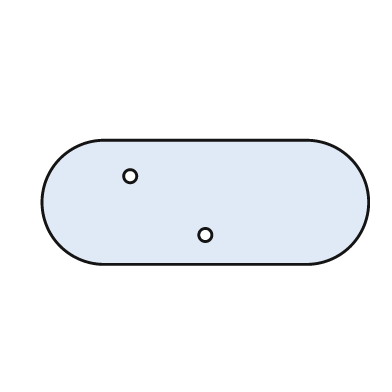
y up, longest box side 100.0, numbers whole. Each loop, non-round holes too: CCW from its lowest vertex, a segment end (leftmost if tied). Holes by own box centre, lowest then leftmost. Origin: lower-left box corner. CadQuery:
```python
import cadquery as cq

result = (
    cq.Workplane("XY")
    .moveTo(19.0, 0.0)
    .lineTo(81.0, 0.0)
    .threePointArc((100.0, 19.0), (81.0, 38.0))
    .lineTo(19.0, 38.0)
    .threePointArc((0.0, 19.0), (19.0, 0.0))
    .close()
    .moveTo(50.0, 9.0)
    .circle(2.0)
    .moveTo(27.0, 27.0)
    .circle(2.0)
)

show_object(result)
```